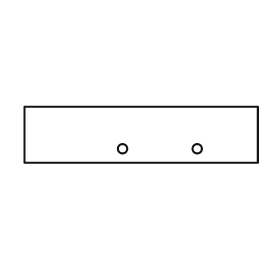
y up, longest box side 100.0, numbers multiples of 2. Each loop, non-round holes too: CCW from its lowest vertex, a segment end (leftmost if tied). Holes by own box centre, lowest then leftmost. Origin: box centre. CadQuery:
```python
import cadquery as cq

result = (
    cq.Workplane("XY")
    .moveTo(-50.0, -12.0)
    .lineTo(50.0, -12.0)
    .lineTo(50.0, 12.0)
    .lineTo(-50.0, 12.0)
    .close()
    .moveTo(-8.0, -6.0)
    .circle(2.0)
    .moveTo(24.0, -6.0)
    .circle(2.0)
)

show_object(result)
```